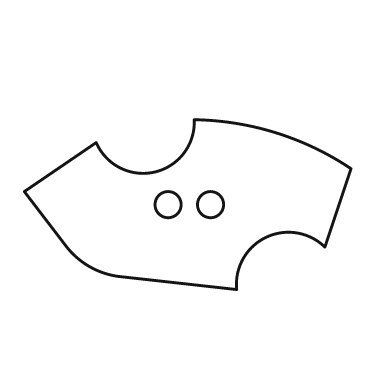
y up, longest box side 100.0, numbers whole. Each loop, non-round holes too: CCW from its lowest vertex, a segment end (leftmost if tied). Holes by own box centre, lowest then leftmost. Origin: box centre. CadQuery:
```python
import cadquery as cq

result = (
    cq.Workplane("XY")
    .moveTo(15.0, -26.0)
    .threePointArc((24.0, -10.0), (42.0, -13.0))
    .lineTo(50.0, 11.0)
    .threePointArc((27.0, 22.0), (2.0, 26.0))
    .threePointArc((-10.0, 10.0), (-28.0, 19.0))
    .lineTo(-50.0, 4.0)
    .lineTo(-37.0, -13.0)
    .threePointArc((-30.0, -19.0), (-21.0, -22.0))
    .close()
    .moveTo(-6.0, 0.0)
    .circle(4.0)
    .moveTo(7.0, 0.0)
    .circle(4.0)
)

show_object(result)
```